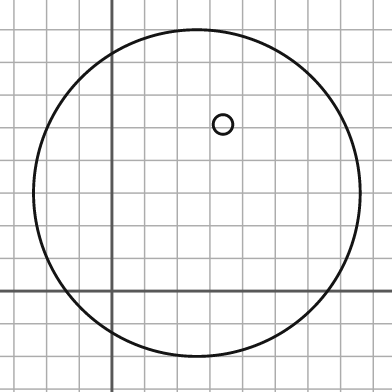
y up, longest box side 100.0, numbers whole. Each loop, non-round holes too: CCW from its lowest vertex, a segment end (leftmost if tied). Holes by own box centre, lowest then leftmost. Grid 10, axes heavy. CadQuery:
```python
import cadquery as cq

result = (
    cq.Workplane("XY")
    .moveTo(26.0, 30.0)
    .circle(50.0)
    .moveTo(34.0, 51.0)
    .circle(3.0)
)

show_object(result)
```